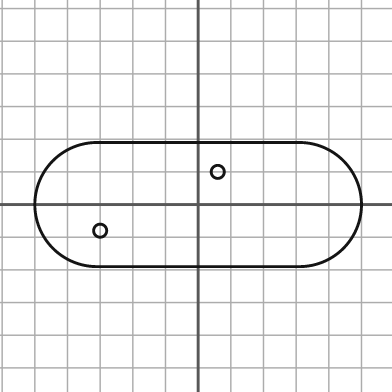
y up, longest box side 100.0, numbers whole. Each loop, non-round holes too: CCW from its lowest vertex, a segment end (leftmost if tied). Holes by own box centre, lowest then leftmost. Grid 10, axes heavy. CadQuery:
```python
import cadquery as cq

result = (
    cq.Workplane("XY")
    .moveTo(-31.0, -19.0)
    .lineTo(31.0, -19.0)
    .threePointArc((50.0, 0.0), (31.0, 19.0))
    .lineTo(-31.0, 19.0)
    .threePointArc((-50.0, 0.0), (-31.0, -19.0))
    .close()
    .moveTo(-30.0, -8.0)
    .circle(2.0)
    .moveTo(6.0, 10.0)
    .circle(2.0)
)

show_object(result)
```